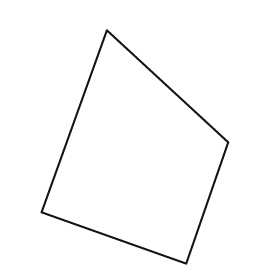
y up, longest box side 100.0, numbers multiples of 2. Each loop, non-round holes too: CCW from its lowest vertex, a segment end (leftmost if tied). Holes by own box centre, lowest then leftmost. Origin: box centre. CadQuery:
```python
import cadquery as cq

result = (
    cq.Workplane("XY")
    .moveTo(22.0, -50.0)
    .lineTo(40.0, 2.0)
    .lineTo(-12.0, 50.0)
    .lineTo(-40.0, -28.0)
    .close()
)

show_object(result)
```